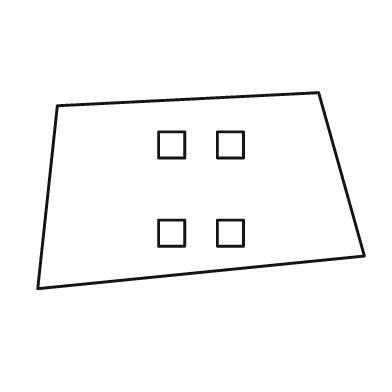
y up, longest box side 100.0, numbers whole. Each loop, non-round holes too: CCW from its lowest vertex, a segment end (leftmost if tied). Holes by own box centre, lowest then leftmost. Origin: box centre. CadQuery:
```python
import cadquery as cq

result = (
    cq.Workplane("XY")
    .moveTo(-50.0, -30.0)
    .lineTo(50.0, -20.0)
    .lineTo(36.0, 30.0)
    .lineTo(-44.0, 26.0)
    .close()
    .moveTo(-13.0, -17.0)
    .lineTo(-5.0, -17.0)
    .lineTo(-5.0, -9.0)
    .lineTo(-13.0, -9.0)
    .close()
    .moveTo(5.0, -17.0)
    .lineTo(13.0, -17.0)
    .lineTo(13.0, -9.0)
    .lineTo(5.0, -9.0)
    .close()
    .moveTo(-13.0, 10.0)
    .lineTo(-5.0, 10.0)
    .lineTo(-5.0, 18.0)
    .lineTo(-13.0, 18.0)
    .close()
    .moveTo(5.0, 10.0)
    .lineTo(13.0, 10.0)
    .lineTo(13.0, 18.0)
    .lineTo(5.0, 18.0)
    .close()
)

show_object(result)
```